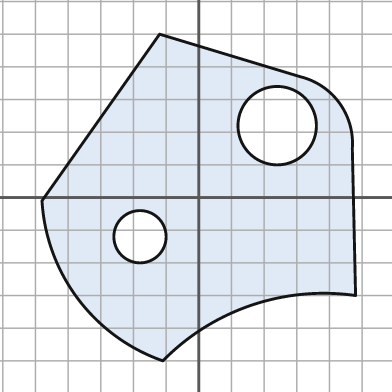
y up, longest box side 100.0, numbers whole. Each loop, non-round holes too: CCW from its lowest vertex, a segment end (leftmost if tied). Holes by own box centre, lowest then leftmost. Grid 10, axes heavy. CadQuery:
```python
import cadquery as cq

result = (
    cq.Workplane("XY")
    .moveTo(-11.0, -50.0)
    .threePointArc((16.0, -33.0), (48.0, -30.0))
    .lineTo(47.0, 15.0)
    .threePointArc((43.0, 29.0), (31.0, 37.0))
    .lineTo(-12.0, 50.0)
    .lineTo(-48.0, -1.0)
    .threePointArc((-37.0, -31.0), (-11.0, -50.0))
    .close()
    .moveTo(-18.0, -12.0)
    .circle(8.0)
    .moveTo(24.0, 22.0)
    .circle(12.0)
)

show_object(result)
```